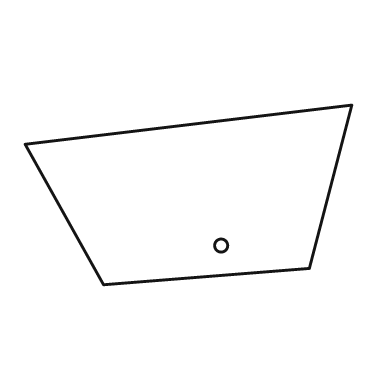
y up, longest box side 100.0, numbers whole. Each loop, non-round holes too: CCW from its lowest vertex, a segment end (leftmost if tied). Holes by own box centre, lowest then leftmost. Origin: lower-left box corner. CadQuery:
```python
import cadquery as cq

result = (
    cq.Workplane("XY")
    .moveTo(24.0, 0.0)
    .lineTo(87.0, 5.0)
    .lineTo(100.0, 55.0)
    .lineTo(0.0, 43.0)
    .close()
    .moveTo(60.0, 12.0)
    .circle(2.0)
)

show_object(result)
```